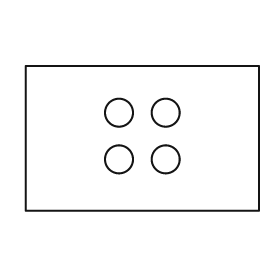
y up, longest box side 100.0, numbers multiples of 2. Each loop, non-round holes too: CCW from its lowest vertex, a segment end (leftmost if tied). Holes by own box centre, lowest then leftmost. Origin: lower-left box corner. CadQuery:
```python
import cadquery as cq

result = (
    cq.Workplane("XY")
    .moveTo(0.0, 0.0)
    .lineTo(100.0, 0.0)
    .lineTo(100.0, 62.0)
    .lineTo(0.0, 62.0)
    .close()
    .moveTo(40.0, 22.0)
    .circle(6.0)
    .moveTo(60.0, 22.0)
    .circle(6.0)
    .moveTo(40.0, 42.0)
    .circle(6.0)
    .moveTo(60.0, 42.0)
    .circle(6.0)
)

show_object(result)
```